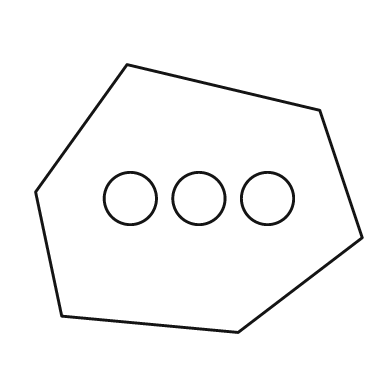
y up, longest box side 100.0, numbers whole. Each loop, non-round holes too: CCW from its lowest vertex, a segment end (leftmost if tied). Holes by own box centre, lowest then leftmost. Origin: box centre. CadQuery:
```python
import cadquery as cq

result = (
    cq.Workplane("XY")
    .moveTo(12.0, -41.0)
    .lineTo(50.0, -12.0)
    .lineTo(37.0, 27.0)
    .lineTo(-22.0, 41.0)
    .lineTo(-50.0, 2.0)
    .lineTo(-42.0, -36.0)
    .close()
    .moveTo(-21.0, 0.0)
    .circle(8.0)
    .moveTo(0.0, 0.0)
    .circle(8.0)
    .moveTo(21.0, 0.0)
    .circle(8.0)
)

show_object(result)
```